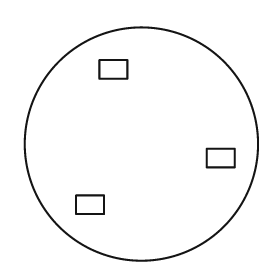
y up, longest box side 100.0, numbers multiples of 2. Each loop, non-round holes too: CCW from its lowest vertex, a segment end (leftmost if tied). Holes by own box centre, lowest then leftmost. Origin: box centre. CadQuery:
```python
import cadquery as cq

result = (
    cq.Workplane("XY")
    .moveTo(0.0, 0.0)
    .circle(50.0)
    .moveTo(-28.0, -30.0)
    .lineTo(-16.0, -30.0)
    .lineTo(-16.0, -22.0)
    .lineTo(-28.0, -22.0)
    .close()
    .moveTo(28.0, -10.0)
    .lineTo(40.0, -10.0)
    .lineTo(40.0, -2.0)
    .lineTo(28.0, -2.0)
    .close()
    .moveTo(-18.0, 28.0)
    .lineTo(-6.0, 28.0)
    .lineTo(-6.0, 36.0)
    .lineTo(-18.0, 36.0)
    .close()
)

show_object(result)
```